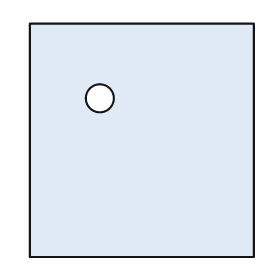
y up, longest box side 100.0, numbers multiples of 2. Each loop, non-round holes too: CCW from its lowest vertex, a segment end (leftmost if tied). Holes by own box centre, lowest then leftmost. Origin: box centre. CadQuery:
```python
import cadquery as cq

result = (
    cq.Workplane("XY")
    .moveTo(-48.0, -50.0)
    .lineTo(48.0, -50.0)
    .lineTo(48.0, 50.0)
    .lineTo(-48.0, 50.0)
    .close()
    .moveTo(-18.0, 18.0)
    .circle(6.0)
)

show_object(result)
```